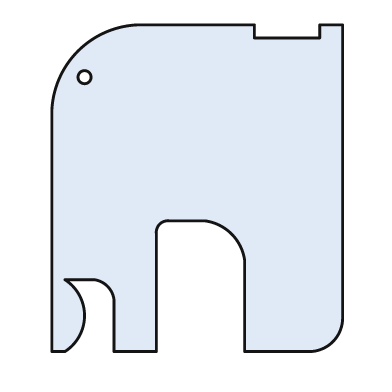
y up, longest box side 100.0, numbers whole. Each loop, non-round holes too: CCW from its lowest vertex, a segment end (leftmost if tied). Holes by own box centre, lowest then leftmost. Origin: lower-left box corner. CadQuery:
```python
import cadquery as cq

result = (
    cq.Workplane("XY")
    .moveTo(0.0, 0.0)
    .lineTo(4.0, 0.0)
    .threePointArc((10.0, 11.0), (4.0, 22.0))
    .lineTo(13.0, 22.0)
    .threePointArc((17.0, 20.0), (19.0, 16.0))
    .lineTo(19.0, 0.0)
    .lineTo(32.0, 0.0)
    .lineTo(32.0, 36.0)
    .threePointArc((33.0, 39.0), (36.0, 40.0))
    .lineTo(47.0, 40.0)
    .threePointArc((55.0, 36.0), (59.0, 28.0))
    .lineTo(59.0, 0.0)
    .lineTo(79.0, 0.0)
    .threePointArc((86.0, 3.0), (89.0, 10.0))
    .lineTo(89.0, 100.0)
    .lineTo(82.0, 100.0)
    .lineTo(82.0, 96.0)
    .lineTo(62.0, 96.0)
    .lineTo(62.0, 100.0)
    .lineTo(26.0, 100.0)
    .threePointArc((8.0, 92.0), (0.0, 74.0))
    .close()
    .moveTo(10.0, 84.0)
    .circle(2.0)
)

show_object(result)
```